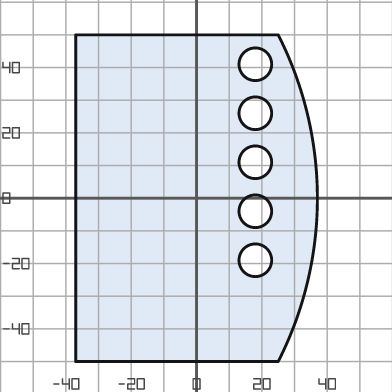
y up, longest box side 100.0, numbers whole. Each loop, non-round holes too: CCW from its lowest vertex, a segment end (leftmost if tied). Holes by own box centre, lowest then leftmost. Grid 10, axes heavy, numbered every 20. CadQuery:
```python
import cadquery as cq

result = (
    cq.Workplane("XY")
    .moveTo(-37.0, -50.0)
    .lineTo(25.0, -50.0)
    .threePointArc((37.0, 0.0), (25.0, 50.0))
    .lineTo(-37.0, 50.0)
    .close()
    .moveTo(18.0, -19.0)
    .circle(5.0)
    .moveTo(18.0, -4.0)
    .circle(5.0)
    .moveTo(18.0, 11.0)
    .circle(5.0)
    .moveTo(18.0, 26.0)
    .circle(5.0)
    .moveTo(18.0, 41.0)
    .circle(5.0)
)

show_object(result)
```